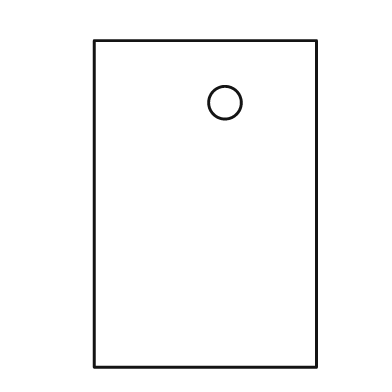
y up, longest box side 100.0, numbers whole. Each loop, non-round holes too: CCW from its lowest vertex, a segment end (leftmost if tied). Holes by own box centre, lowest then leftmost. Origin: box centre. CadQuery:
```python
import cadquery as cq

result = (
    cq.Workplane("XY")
    .moveTo(-34.0, -50.0)
    .lineTo(34.0, -50.0)
    .lineTo(34.0, 50.0)
    .lineTo(-34.0, 50.0)
    .close()
    .moveTo(6.0, 31.0)
    .circle(5.0)
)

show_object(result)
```